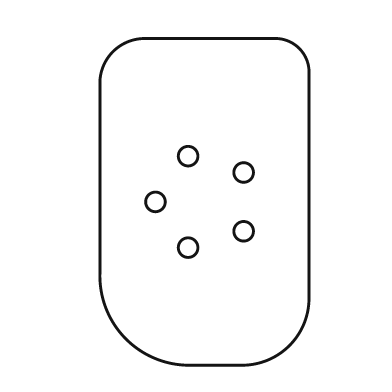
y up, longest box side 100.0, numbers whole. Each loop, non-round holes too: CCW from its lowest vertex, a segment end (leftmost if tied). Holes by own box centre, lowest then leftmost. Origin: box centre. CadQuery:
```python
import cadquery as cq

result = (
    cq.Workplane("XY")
    .moveTo(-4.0, -50.0)
    .lineTo(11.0, -50.0)
    .threePointArc((26.0, -44.0), (32.0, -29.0))
    .lineTo(32.0, 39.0)
    .threePointArc((29.0, 47.0), (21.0, 50.0))
    .lineTo(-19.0, 50.0)
    .threePointArc((-28.0, 46.0), (-32.0, 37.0))
    .lineTo(-32.0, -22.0)
    .threePointArc((-24.0, -42.0), (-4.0, -50.0))
    .close()
    .moveTo(-5.0, -14.0)
    .circle(3.0)
    .moveTo(12.0, -9.0)
    .circle(3.0)
    .moveTo(-15.0, 0.0)
    .circle(3.0)
    .moveTo(12.0, 9.0)
    .circle(3.0)
    .moveTo(-5.0, 14.0)
    .circle(3.0)
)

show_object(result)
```